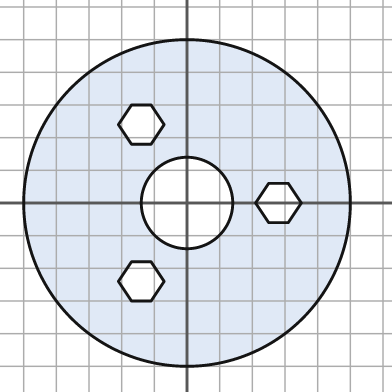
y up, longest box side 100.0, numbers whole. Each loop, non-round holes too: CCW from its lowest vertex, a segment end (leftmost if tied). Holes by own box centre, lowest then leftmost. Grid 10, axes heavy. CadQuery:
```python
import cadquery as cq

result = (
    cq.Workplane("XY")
    .moveTo(0.0, 0.0)
    .circle(50.0)
    .moveTo(-17.0, -30.0)
    .lineTo(-11.0, -30.0)
    .lineTo(-7.0, -24.0)
    .lineTo(-11.0, -18.0)
    .lineTo(-17.0, -18.0)
    .lineTo(-21.0, -24.0)
    .close()
    .moveTo(0.0, 0.0)
    .circle(14.0)
    .moveTo(25.0, -6.0)
    .lineTo(31.0, -6.0)
    .lineTo(35.0, 0.0)
    .lineTo(31.0, 6.0)
    .lineTo(25.0, 6.0)
    .lineTo(21.0, 0.0)
    .close()
    .moveTo(-17.0, 18.0)
    .lineTo(-11.0, 18.0)
    .lineTo(-7.0, 24.0)
    .lineTo(-11.0, 30.0)
    .lineTo(-17.0, 30.0)
    .lineTo(-21.0, 24.0)
    .close()
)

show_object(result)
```